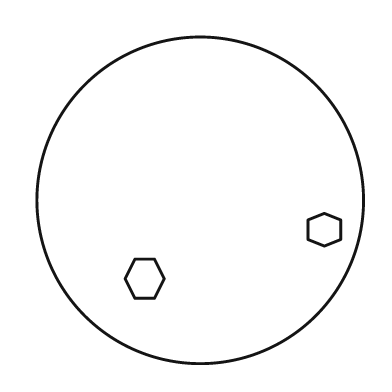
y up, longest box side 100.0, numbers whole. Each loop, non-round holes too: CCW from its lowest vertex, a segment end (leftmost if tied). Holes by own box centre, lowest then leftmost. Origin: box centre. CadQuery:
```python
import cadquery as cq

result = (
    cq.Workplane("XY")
    .moveTo(0.0, 0.0)
    .circle(50.0)
    .moveTo(-20.0, -30.0)
    .lineTo(-14.0, -30.0)
    .lineTo(-11.0, -24.0)
    .lineTo(-14.0, -18.0)
    .lineTo(-20.0, -18.0)
    .lineTo(-23.0, -24.0)
    .close()
    .moveTo(38.0, -14.0)
    .lineTo(43.0, -12.0)
    .lineTo(43.0, -6.0)
    .lineTo(38.0, -4.0)
    .lineTo(33.0, -6.0)
    .lineTo(33.0, -12.0)
    .close()
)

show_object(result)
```